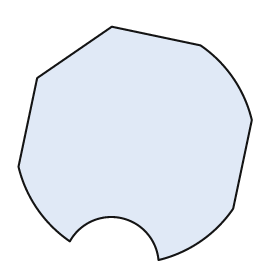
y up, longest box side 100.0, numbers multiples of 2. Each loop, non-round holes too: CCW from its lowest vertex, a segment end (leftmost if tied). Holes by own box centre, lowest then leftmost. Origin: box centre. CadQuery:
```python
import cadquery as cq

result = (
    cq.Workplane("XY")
    .moveTo(10.0, -50.0)
    .threePointArc((28.0, -42.0), (42.0, -28.0))
    .lineTo(50.0, 10.0)
    .threePointArc((42.0, 28.0), (28.0, 42.0))
    .lineTo(-10.0, 50.0)
    .lineTo(-42.0, 28.0)
    .lineTo(-50.0, -10.0)
    .threePointArc((-42.0, -28.0), (-28.0, -42.0))
    .threePointArc((-6.0, -32.0), (10.0, -50.0))
    .close()
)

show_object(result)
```